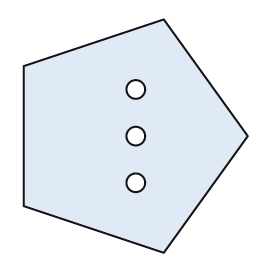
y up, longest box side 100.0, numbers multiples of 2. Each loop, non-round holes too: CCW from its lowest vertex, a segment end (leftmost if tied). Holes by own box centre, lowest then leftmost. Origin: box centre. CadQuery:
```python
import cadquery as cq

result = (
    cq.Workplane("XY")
    .moveTo(12.0, -50.0)
    .lineTo(48.0, 0.0)
    .lineTo(12.0, 50.0)
    .lineTo(-48.0, 30.0)
    .lineTo(-48.0, -30.0)
    .close()
    .moveTo(0.0, -20.0)
    .circle(4.0)
    .moveTo(0.0, 0.0)
    .circle(4.0)
    .moveTo(0.0, 20.0)
    .circle(4.0)
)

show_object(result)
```